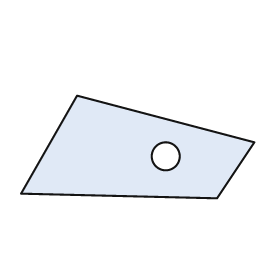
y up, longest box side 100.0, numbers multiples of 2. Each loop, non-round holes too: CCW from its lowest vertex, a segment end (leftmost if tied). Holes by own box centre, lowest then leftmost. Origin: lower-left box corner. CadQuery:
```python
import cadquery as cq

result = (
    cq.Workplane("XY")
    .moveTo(84.0, 0.0)
    .lineTo(100.0, 24.0)
    .lineTo(24.0, 44.0)
    .lineTo(0.0, 2.0)
    .close()
    .moveTo(62.0, 18.0)
    .circle(6.0)
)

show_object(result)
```